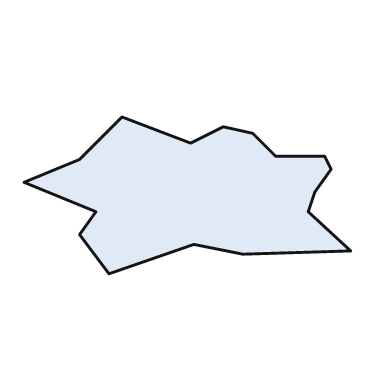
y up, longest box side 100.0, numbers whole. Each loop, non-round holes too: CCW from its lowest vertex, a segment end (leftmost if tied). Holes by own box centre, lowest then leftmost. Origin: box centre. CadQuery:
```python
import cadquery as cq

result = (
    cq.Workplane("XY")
    .moveTo(-24.0, -24.0)
    .lineTo(2.0, -15.0)
    .lineTo(17.0, -18.0)
    .lineTo(50.0, -17.0)
    .lineTo(37.0, -5.0)
    .lineTo(39.0, 1.0)
    .lineTo(44.0, 8.0)
    .lineTo(42.0, 12.0)
    .lineTo(27.0, 12.0)
    .lineTo(20.0, 19.0)
    .lineTo(11.0, 21.0)
    .lineTo(1.0, 16.0)
    .lineTo(-20.0, 24.0)
    .lineTo(-33.0, 11.0)
    .lineTo(-50.0, 4.0)
    .lineTo(-28.0, -5.0)
    .lineTo(-33.0, -12.0)
    .close()
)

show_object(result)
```